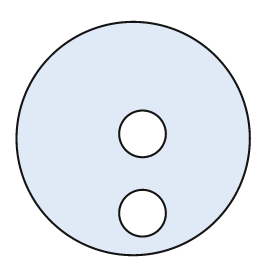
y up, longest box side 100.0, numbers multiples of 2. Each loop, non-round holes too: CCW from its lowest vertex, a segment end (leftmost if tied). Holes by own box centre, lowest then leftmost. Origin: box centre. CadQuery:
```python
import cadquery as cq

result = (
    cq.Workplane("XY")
    .moveTo(0.0, 0.0)
    .circle(50.0)
    .moveTo(4.0, -32.0)
    .circle(10.0)
    .moveTo(4.0, 2.0)
    .circle(10.0)
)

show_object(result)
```